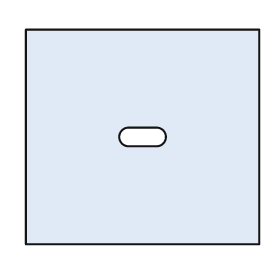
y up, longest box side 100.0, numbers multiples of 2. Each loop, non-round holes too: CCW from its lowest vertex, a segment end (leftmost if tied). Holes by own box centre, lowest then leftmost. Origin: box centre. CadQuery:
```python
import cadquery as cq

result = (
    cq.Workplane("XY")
    .moveTo(-50.0, -46.0)
    .lineTo(50.0, -46.0)
    .lineTo(50.0, 46.0)
    .lineTo(-50.0, 46.0)
    .close()
    .moveTo(-6.0, -4.0)
    .lineTo(6.0, -4.0)
    .threePointArc((10.0, 0.0), (6.0, 4.0))
    .lineTo(-6.0, 4.0)
    .threePointArc((-10.0, 0.0), (-6.0, -4.0))
    .close()
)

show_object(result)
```